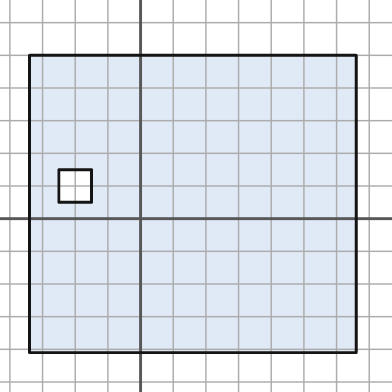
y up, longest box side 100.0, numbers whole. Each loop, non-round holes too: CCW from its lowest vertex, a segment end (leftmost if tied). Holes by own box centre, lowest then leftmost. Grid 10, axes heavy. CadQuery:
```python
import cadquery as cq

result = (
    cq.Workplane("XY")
    .moveTo(-34.0, -41.0)
    .lineTo(66.0, -41.0)
    .lineTo(66.0, 50.0)
    .lineTo(-34.0, 50.0)
    .close()
    .moveTo(-25.0, 5.0)
    .lineTo(-15.0, 5.0)
    .lineTo(-15.0, 15.0)
    .lineTo(-25.0, 15.0)
    .close()
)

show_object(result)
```